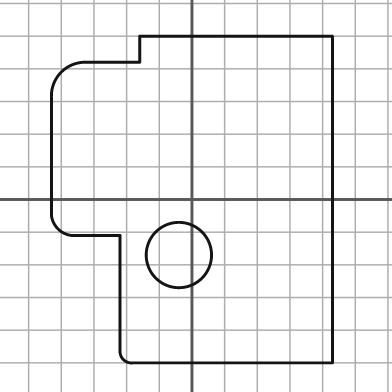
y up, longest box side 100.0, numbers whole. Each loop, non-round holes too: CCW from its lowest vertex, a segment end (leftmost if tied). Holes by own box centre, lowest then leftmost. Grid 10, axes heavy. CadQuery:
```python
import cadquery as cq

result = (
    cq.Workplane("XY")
    .moveTo(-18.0, -50.0)
    .lineTo(43.0, -50.0)
    .lineTo(43.0, 50.0)
    .lineTo(-16.0, 50.0)
    .lineTo(-16.0, 42.0)
    .lineTo(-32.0, 42.0)
    .threePointArc((-40.0, 39.0), (-43.0, 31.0))
    .lineTo(-43.0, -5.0)
    .threePointArc((-41.0, -9.0), (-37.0, -11.0))
    .lineTo(-22.0, -11.0)
    .lineTo(-22.0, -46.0)
    .threePointArc((-21.0, -49.0), (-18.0, -50.0))
    .close()
    .moveTo(-4.0, -17.0)
    .circle(10.0)
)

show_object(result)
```